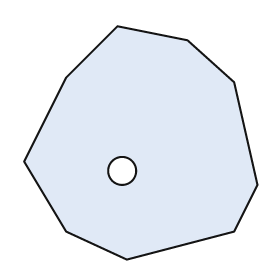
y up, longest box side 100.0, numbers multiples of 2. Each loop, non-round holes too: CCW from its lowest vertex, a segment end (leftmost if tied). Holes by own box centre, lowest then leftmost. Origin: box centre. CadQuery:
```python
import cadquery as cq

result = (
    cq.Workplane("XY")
    .moveTo(-6.0, -50.0)
    .lineTo(40.0, -38.0)
    .lineTo(50.0, -18.0)
    .lineTo(40.0, 26.0)
    .lineTo(20.0, 44.0)
    .lineTo(-10.0, 50.0)
    .lineTo(-32.0, 28.0)
    .lineTo(-50.0, -8.0)
    .lineTo(-32.0, -38.0)
    .close()
    .moveTo(-8.0, -12.0)
    .circle(6.0)
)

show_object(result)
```